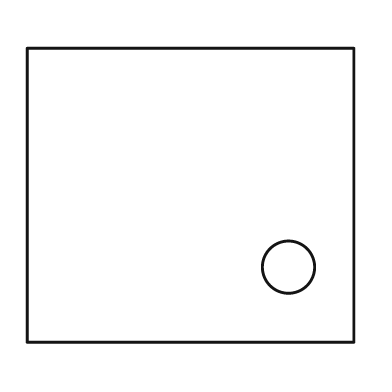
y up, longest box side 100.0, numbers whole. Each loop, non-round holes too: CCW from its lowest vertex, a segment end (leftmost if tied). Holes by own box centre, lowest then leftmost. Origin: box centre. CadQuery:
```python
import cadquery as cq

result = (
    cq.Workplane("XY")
    .moveTo(-50.0, -45.0)
    .lineTo(50.0, -45.0)
    .lineTo(50.0, 45.0)
    .lineTo(-50.0, 45.0)
    .close()
    .moveTo(30.0, -22.0)
    .circle(8.0)
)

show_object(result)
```